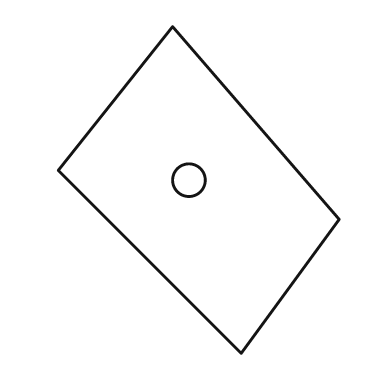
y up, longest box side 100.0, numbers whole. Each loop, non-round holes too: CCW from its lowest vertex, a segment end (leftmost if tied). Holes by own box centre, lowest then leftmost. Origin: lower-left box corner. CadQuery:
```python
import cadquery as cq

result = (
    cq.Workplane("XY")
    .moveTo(56.0, 0.0)
    .lineTo(86.0, 41.0)
    .lineTo(35.0, 100.0)
    .lineTo(0.0, 56.0)
    .close()
    .moveTo(40.0, 53.0)
    .circle(5.0)
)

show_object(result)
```